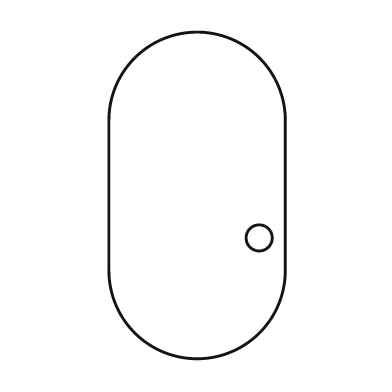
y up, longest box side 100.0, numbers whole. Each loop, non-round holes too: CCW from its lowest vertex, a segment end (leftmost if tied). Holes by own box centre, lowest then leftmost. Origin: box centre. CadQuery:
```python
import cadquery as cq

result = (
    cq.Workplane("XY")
    .moveTo(-27.0, -23.0)
    .threePointArc((0.0, -50.0), (27.0, -23.0))
    .lineTo(27.0, 23.0)
    .threePointArc((0.0, 50.0), (-27.0, 23.0))
    .close()
    .moveTo(19.0, -13.0)
    .circle(4.0)
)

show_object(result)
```